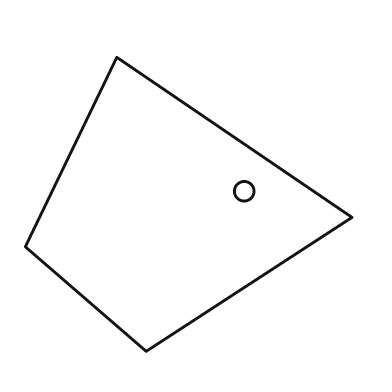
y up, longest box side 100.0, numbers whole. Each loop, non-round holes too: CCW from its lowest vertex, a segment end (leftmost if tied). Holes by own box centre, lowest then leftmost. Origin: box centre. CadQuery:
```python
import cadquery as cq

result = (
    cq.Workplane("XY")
    .moveTo(-13.0, -45.0)
    .lineTo(50.0, -4.0)
    .lineTo(-22.0, 45.0)
    .lineTo(-50.0, -13.0)
    .close()
    .moveTo(17.0, 4.0)
    .circle(3.0)
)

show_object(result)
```